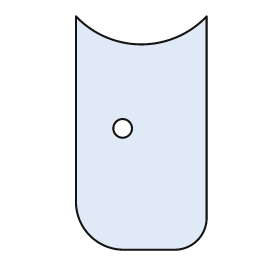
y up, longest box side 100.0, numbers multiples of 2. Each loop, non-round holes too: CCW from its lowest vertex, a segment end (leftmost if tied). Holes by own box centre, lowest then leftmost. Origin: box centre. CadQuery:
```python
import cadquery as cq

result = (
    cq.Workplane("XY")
    .moveTo(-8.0, -50.0)
    .lineTo(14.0, -50.0)
    .threePointArc((24.0, -46.0), (28.0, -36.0))
    .lineTo(28.0, 50.0)
    .threePointArc((0.0, 38.0), (-28.0, 50.0))
    .lineTo(-28.0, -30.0)
    .threePointArc((-22.0, -44.0), (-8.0, -50.0))
    .close()
    .moveTo(-8.0, 2.0)
    .circle(4.0)
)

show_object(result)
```